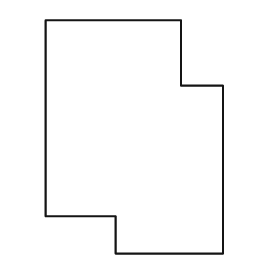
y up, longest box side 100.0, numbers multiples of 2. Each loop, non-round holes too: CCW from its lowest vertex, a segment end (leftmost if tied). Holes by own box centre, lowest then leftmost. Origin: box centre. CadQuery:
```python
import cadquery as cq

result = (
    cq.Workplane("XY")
    .moveTo(-8.0, -50.0)
    .lineTo(38.0, -50.0)
    .lineTo(38.0, 22.0)
    .lineTo(20.0, 22.0)
    .lineTo(20.0, 50.0)
    .lineTo(-38.0, 50.0)
    .lineTo(-38.0, -34.0)
    .lineTo(-8.0, -34.0)
    .close()
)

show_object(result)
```